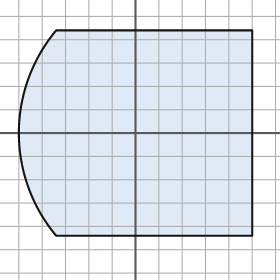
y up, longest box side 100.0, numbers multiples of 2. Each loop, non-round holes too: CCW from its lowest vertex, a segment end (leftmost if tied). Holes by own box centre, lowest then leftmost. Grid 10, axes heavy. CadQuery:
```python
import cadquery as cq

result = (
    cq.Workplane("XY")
    .moveTo(-34.0, -44.0)
    .lineTo(50.0, -44.0)
    .lineTo(50.0, 44.0)
    .lineTo(-34.0, 44.0)
    .threePointArc((-50.0, 0.0), (-34.0, -44.0))
    .close()
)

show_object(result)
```